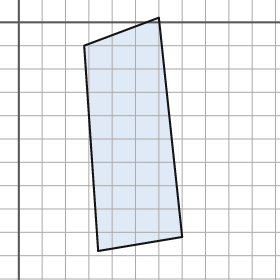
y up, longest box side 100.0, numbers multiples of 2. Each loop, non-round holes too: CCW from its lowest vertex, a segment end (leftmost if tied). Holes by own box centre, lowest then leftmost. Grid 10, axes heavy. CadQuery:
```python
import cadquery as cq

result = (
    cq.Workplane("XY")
    .moveTo(34.0, -98.0)
    .lineTo(70.0, -92.0)
    .lineTo(60.0, 2.0)
    .lineTo(28.0, -10.0)
    .close()
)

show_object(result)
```